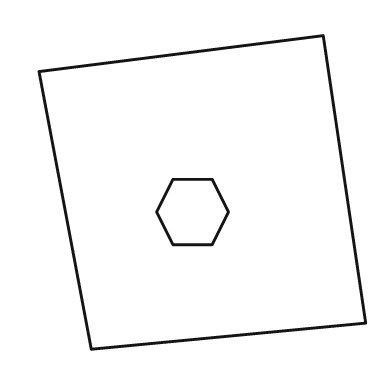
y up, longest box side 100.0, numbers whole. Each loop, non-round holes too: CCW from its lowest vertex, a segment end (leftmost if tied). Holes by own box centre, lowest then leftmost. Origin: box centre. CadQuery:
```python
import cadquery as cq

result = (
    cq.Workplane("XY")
    .moveTo(-34.0, -48.0)
    .lineTo(50.0, -40.0)
    .lineTo(37.0, 48.0)
    .lineTo(-50.0, 37.0)
    .close()
    .moveTo(-9.0, -16.0)
    .lineTo(3.0, -16.0)
    .lineTo(8.0, -6.0)
    .lineTo(3.0, 4.0)
    .lineTo(-9.0, 4.0)
    .lineTo(-14.0, -6.0)
    .close()
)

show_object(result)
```